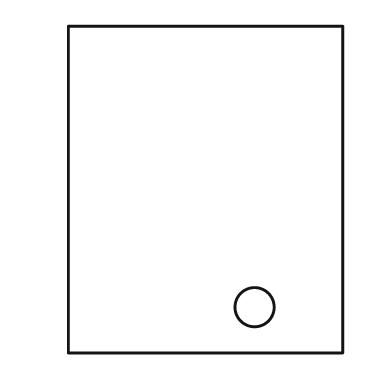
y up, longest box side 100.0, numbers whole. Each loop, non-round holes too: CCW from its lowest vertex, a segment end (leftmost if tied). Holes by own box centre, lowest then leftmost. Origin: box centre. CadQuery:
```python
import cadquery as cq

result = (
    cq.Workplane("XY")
    .moveTo(-42.0, -50.0)
    .lineTo(42.0, -50.0)
    .lineTo(42.0, 50.0)
    .lineTo(-42.0, 50.0)
    .close()
    .moveTo(15.0, -36.0)
    .circle(6.0)
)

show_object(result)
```